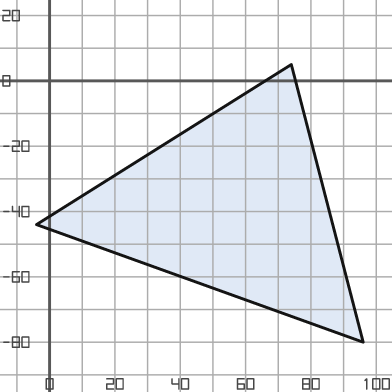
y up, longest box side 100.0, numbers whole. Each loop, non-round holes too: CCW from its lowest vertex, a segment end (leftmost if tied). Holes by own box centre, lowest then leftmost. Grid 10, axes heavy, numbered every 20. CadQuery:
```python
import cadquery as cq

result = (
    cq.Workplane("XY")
    .moveTo(96.0, -80.0)
    .lineTo(74.0, 5.0)
    .lineTo(-4.0, -44.0)
    .close()
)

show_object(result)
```